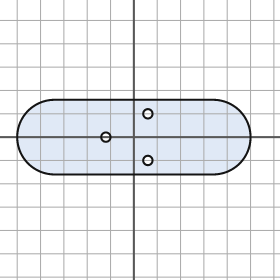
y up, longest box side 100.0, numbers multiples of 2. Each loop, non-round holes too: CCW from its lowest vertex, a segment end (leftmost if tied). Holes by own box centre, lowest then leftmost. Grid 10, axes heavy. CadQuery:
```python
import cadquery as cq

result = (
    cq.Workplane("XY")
    .moveTo(-34.0, -16.0)
    .lineTo(34.0, -16.0)
    .threePointArc((50.0, 0.0), (34.0, 16.0))
    .lineTo(-34.0, 16.0)
    .threePointArc((-50.0, 0.0), (-34.0, -16.0))
    .close()
    .moveTo(6.0, -10.0)
    .circle(2.0)
    .moveTo(-12.0, 0.0)
    .circle(2.0)
    .moveTo(6.0, 10.0)
    .circle(2.0)
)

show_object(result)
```